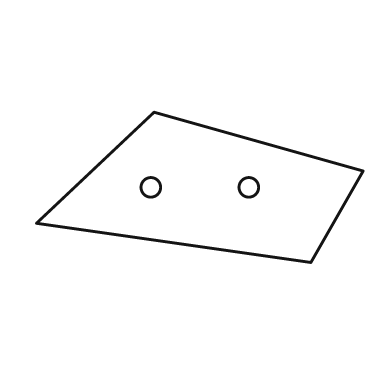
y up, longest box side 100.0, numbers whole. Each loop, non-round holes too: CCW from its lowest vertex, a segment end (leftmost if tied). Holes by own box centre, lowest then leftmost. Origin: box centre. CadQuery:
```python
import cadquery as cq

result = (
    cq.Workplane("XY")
    .moveTo(34.0, -23.0)
    .lineTo(50.0, 5.0)
    .lineTo(-14.0, 23.0)
    .lineTo(-50.0, -11.0)
    .close()
    .moveTo(-15.0, 0.0)
    .circle(3.0)
    .moveTo(15.0, 0.0)
    .circle(3.0)
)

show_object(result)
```